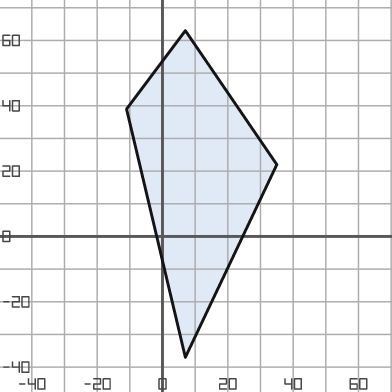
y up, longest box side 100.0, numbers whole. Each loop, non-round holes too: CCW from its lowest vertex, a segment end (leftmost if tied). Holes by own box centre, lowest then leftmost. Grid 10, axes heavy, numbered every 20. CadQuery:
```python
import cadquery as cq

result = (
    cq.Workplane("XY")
    .moveTo(7.0, -37.0)
    .lineTo(35.0, 22.0)
    .lineTo(7.0, 63.0)
    .lineTo(-11.0, 39.0)
    .close()
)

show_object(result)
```